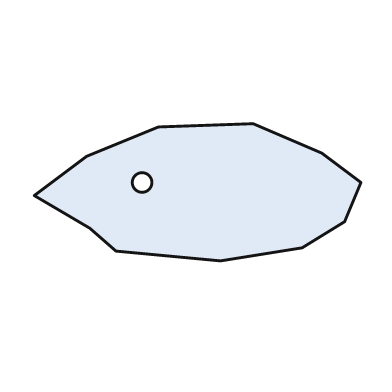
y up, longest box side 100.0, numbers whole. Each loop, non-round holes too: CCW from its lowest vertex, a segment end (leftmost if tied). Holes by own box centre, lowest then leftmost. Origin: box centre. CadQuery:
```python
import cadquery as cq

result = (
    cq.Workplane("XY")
    .moveTo(7.0, -21.0)
    .lineTo(32.0, -17.0)
    .lineTo(45.0, -9.0)
    .lineTo(50.0, 3.0)
    .lineTo(38.0, 12.0)
    .lineTo(17.0, 21.0)
    .lineTo(-12.0, 20.0)
    .lineTo(-34.0, 11.0)
    .lineTo(-50.0, -1.0)
    .lineTo(-33.0, -11.0)
    .lineTo(-25.0, -18.0)
    .close()
    .moveTo(-17.0, 3.0)
    .circle(3.0)
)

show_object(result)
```